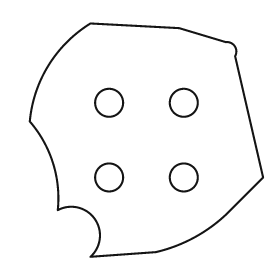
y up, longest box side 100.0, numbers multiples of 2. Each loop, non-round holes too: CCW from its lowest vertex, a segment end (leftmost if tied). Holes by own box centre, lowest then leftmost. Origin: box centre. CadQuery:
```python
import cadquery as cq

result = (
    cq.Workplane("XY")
    .moveTo(-24.0, -50.0)
    .lineTo(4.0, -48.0)
    .threePointArc((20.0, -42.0), (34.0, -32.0))
    .lineTo(50.0, -16.0)
    .lineTo(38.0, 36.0)
    .threePointArc((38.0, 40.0), (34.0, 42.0))
    .lineTo(14.0, 48.0)
    .lineTo(-24.0, 50.0)
    .threePointArc((-42.0, 32.0), (-50.0, 8.0))
    .threePointArc((-40.0, -10.0), (-38.0, -30.0))
    .threePointArc((-22.0, -34.0), (-24.0, -50.0))
    .close()
    .moveTo(-16.0, -16.0)
    .circle(6.0)
    .moveTo(16.0, -16.0)
    .circle(6.0)
    .moveTo(-16.0, 16.0)
    .circle(6.0)
    .moveTo(16.0, 16.0)
    .circle(6.0)
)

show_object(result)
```